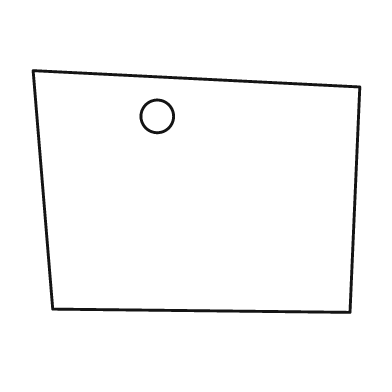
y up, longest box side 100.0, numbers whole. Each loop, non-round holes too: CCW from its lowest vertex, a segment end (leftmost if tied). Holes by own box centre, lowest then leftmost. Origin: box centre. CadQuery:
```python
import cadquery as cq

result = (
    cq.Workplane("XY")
    .moveTo(47.0, -37.0)
    .lineTo(50.0, 32.0)
    .lineTo(-50.0, 37.0)
    .lineTo(-44.0, -36.0)
    .close()
    .moveTo(-12.0, 23.0)
    .circle(5.0)
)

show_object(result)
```